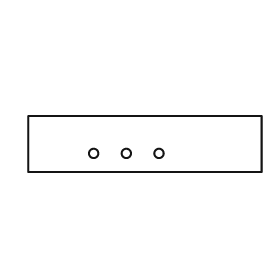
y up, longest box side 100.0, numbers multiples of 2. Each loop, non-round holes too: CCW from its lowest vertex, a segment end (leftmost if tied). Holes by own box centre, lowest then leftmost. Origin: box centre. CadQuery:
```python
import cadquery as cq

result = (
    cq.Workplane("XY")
    .moveTo(-50.0, -12.0)
    .lineTo(50.0, -12.0)
    .lineTo(50.0, 12.0)
    .lineTo(-50.0, 12.0)
    .close()
    .moveTo(-22.0, -4.0)
    .circle(2.0)
    .moveTo(-8.0, -4.0)
    .circle(2.0)
    .moveTo(6.0, -4.0)
    .circle(2.0)
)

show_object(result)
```